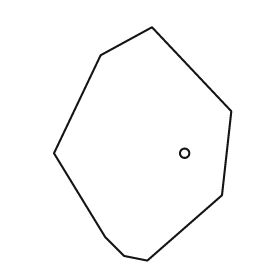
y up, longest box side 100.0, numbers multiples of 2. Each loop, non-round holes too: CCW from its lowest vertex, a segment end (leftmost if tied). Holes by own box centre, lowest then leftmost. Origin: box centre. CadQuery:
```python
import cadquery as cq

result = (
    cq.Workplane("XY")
    .moveTo(2.0, -50.0)
    .lineTo(34.0, -22.0)
    .lineTo(38.0, 14.0)
    .lineTo(4.0, 50.0)
    .lineTo(-18.0, 38.0)
    .lineTo(-38.0, -4.0)
    .lineTo(-16.0, -40.0)
    .lineTo(-8.0, -48.0)
    .close()
    .moveTo(18.0, -4.0)
    .circle(2.0)
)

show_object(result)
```